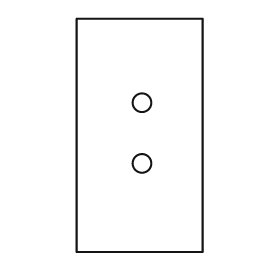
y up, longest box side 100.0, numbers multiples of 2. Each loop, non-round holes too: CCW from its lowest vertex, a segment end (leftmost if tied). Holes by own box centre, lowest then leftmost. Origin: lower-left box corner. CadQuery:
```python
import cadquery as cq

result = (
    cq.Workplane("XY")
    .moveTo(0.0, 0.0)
    .lineTo(54.0, 0.0)
    .lineTo(54.0, 100.0)
    .lineTo(0.0, 100.0)
    .close()
    .moveTo(28.0, 38.0)
    .circle(4.0)
    .moveTo(28.0, 64.0)
    .circle(4.0)
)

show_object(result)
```